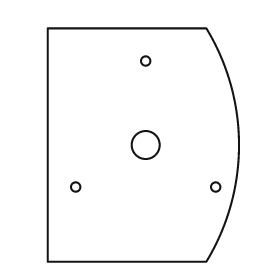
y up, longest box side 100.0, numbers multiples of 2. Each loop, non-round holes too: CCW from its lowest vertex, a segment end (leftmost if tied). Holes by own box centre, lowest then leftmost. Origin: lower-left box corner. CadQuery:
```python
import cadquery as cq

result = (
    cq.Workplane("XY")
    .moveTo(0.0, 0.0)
    .lineTo(68.0, 0.0)
    .threePointArc((82.0, 50.0), (68.0, 100.0))
    .lineTo(0.0, 100.0)
    .close()
    .moveTo(12.0, 32.0)
    .circle(2.0)
    .moveTo(72.0, 32.0)
    .circle(2.0)
    .moveTo(42.0, 50.0)
    .circle(6.0)
    .moveTo(42.0, 86.0)
    .circle(2.0)
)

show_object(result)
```